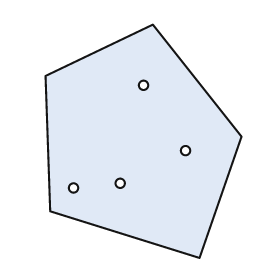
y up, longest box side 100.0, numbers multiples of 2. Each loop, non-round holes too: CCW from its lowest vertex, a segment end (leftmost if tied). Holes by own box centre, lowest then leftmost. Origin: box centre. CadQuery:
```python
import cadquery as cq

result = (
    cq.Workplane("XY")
    .moveTo(24.0, -50.0)
    .lineTo(42.0, 2.0)
    .lineTo(4.0, 50.0)
    .lineTo(-42.0, 28.0)
    .lineTo(-40.0, -30.0)
    .close()
    .moveTo(-30.0, -20.0)
    .circle(2.0)
    .moveTo(-10.0, -18.0)
    .circle(2.0)
    .moveTo(18.0, -4.0)
    .circle(2.0)
    .moveTo(0.0, 24.0)
    .circle(2.0)
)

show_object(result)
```